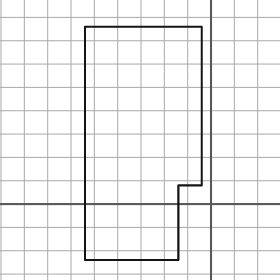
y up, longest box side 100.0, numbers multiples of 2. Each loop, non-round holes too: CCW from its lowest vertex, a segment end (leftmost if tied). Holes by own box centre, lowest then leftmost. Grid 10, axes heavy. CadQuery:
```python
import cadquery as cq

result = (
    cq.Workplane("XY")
    .moveTo(-54.0, -24.0)
    .lineTo(-14.0, -24.0)
    .lineTo(-14.0, 8.0)
    .lineTo(-4.0, 8.0)
    .lineTo(-4.0, 76.0)
    .lineTo(-54.0, 76.0)
    .close()
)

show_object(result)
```